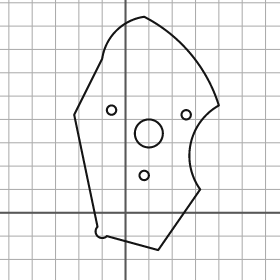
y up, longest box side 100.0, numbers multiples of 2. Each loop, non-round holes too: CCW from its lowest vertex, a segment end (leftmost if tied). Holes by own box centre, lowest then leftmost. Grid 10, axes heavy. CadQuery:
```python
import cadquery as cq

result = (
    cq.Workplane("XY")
    .moveTo(14.0, -16.0)
    .lineTo(32.0, 10.0)
    .threePointArc((28.0, 30.0), (40.0, 46.0))
    .threePointArc((28.0, 68.0), (8.0, 84.0))
    .threePointArc((-4.0, 78.0), (-10.0, 66.0))
    .lineTo(-22.0, 42.0)
    .lineTo(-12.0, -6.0)
    .threePointArc((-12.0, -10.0), (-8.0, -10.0))
    .close()
    .moveTo(8.0, 16.0)
    .circle(2.0)
    .moveTo(10.0, 34.0)
    .circle(6.0)
    .moveTo(26.0, 42.0)
    .circle(2.0)
    .moveTo(-6.0, 44.0)
    .circle(2.0)
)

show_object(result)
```